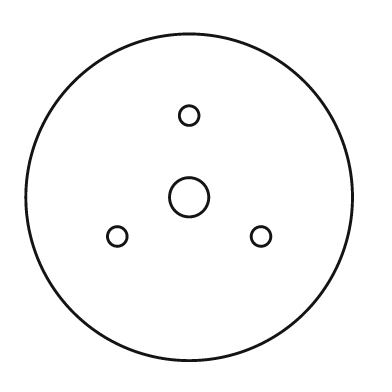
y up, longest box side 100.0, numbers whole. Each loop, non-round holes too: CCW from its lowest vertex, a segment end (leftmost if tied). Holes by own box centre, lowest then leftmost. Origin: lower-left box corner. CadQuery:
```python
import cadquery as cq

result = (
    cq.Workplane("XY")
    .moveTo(50.0, 50.0)
    .circle(50.0)
    .moveTo(28.0, 38.0)
    .circle(3.0)
    .moveTo(72.0, 38.0)
    .circle(3.0)
    .moveTo(50.0, 50.0)
    .circle(6.0)
    .moveTo(50.0, 75.0)
    .circle(3.0)
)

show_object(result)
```